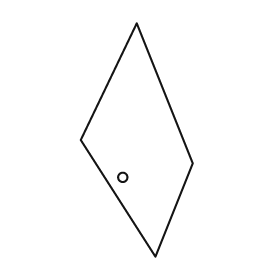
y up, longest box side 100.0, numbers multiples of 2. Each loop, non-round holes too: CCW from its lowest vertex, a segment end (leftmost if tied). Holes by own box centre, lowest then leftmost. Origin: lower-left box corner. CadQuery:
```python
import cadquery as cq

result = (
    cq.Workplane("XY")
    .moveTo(32.0, 0.0)
    .lineTo(48.0, 40.0)
    .lineTo(24.0, 100.0)
    .lineTo(0.0, 50.0)
    .close()
    .moveTo(18.0, 34.0)
    .circle(2.0)
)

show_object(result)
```